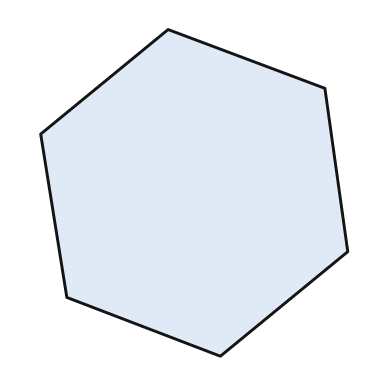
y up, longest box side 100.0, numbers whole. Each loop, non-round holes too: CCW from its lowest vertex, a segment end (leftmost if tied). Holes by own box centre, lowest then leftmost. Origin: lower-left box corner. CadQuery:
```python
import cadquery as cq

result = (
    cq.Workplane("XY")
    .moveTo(55.0, 0.0)
    .lineTo(94.0, 32.0)
    .lineTo(87.0, 82.0)
    .lineTo(39.0, 100.0)
    .lineTo(0.0, 68.0)
    .lineTo(8.0, 18.0)
    .close()
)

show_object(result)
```